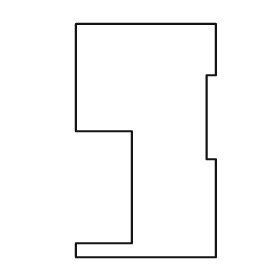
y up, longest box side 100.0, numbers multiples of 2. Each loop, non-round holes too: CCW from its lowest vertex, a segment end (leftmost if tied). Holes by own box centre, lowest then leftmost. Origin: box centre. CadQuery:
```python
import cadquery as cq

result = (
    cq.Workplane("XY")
    .moveTo(-30.0, -50.0)
    .lineTo(30.0, -50.0)
    .lineTo(30.0, -8.0)
    .lineTo(26.0, -8.0)
    .lineTo(26.0, 28.0)
    .lineTo(30.0, 28.0)
    .lineTo(30.0, 50.0)
    .lineTo(-30.0, 50.0)
    .lineTo(-30.0, 4.0)
    .lineTo(-6.0, 4.0)
    .lineTo(-6.0, -44.0)
    .lineTo(-30.0, -44.0)
    .close()
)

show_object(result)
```